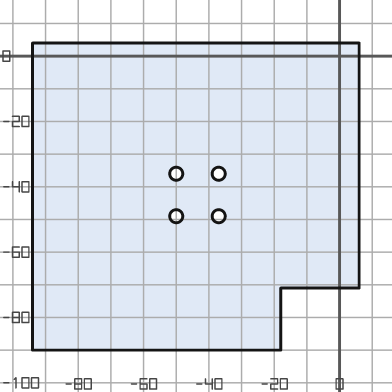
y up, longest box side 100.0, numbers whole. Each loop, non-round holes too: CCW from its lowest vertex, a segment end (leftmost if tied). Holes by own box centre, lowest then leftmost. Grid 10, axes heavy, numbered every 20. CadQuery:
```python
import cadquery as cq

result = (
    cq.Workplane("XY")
    .moveTo(-94.0, -90.0)
    .lineTo(-18.0, -90.0)
    .lineTo(-18.0, -71.0)
    .lineTo(6.0, -71.0)
    .lineTo(6.0, 4.0)
    .lineTo(-94.0, 4.0)
    .close()
    .moveTo(-50.0, -49.0)
    .circle(2.0)
    .moveTo(-37.0, -49.0)
    .circle(2.0)
    .moveTo(-50.0, -36.0)
    .circle(2.0)
    .moveTo(-37.0, -36.0)
    .circle(2.0)
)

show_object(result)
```